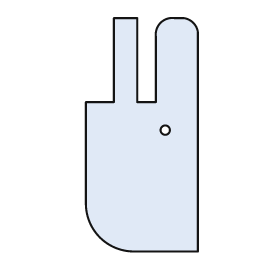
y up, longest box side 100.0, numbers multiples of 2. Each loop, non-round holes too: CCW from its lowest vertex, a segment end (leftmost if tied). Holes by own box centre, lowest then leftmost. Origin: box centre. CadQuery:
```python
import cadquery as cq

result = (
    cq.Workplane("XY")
    .moveTo(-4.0, -50.0)
    .lineTo(24.0, -50.0)
    .lineTo(24.0, 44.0)
    .threePointArc((22.0, 48.0), (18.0, 50.0))
    .lineTo(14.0, 50.0)
    .threePointArc((8.0, 48.0), (6.0, 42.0))
    .lineTo(6.0, 14.0)
    .lineTo(-2.0, 14.0)
    .lineTo(-2.0, 50.0)
    .lineTo(-12.0, 50.0)
    .lineTo(-12.0, 14.0)
    .lineTo(-24.0, 14.0)
    .lineTo(-24.0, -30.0)
    .threePointArc((-18.0, -44.0), (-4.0, -50.0))
    .close()
    .moveTo(10.0, 2.0)
    .circle(2.0)
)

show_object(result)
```